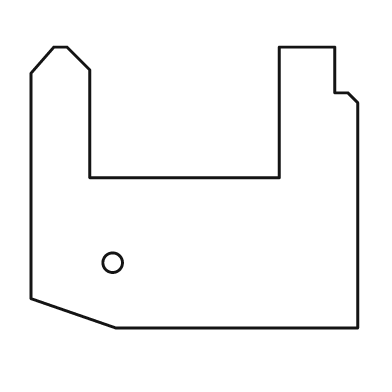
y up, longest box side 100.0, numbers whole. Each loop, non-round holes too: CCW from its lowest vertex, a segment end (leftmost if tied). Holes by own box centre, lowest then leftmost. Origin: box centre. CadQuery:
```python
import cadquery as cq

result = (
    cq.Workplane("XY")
    .moveTo(-24.0, -43.0)
    .lineTo(50.0, -43.0)
    .lineTo(50.0, 26.0)
    .lineTo(47.0, 29.0)
    .lineTo(43.0, 29.0)
    .lineTo(43.0, 43.0)
    .lineTo(26.0, 43.0)
    .lineTo(26.0, 3.0)
    .lineTo(-32.0, 3.0)
    .lineTo(-32.0, 36.0)
    .lineTo(-39.0, 43.0)
    .lineTo(-43.0, 43.0)
    .lineTo(-50.0, 35.0)
    .lineTo(-50.0, -34.0)
    .close()
    .moveTo(-25.0, -23.0)
    .circle(3.0)
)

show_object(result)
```